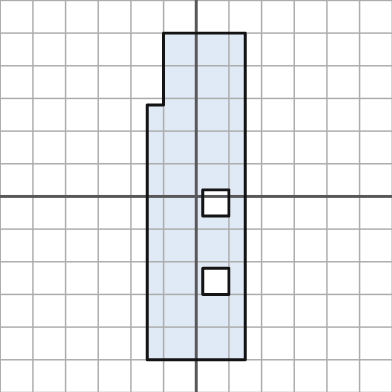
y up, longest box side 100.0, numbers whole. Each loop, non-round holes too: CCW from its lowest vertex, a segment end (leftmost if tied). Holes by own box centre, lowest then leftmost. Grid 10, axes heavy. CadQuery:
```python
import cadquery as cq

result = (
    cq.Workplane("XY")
    .moveTo(-15.0, -50.0)
    .lineTo(15.0, -50.0)
    .lineTo(15.0, 50.0)
    .lineTo(-10.0, 50.0)
    .lineTo(-10.0, 28.0)
    .lineTo(-15.0, 28.0)
    .close()
    .moveTo(2.0, -30.0)
    .lineTo(10.0, -30.0)
    .lineTo(10.0, -22.0)
    .lineTo(2.0, -22.0)
    .close()
    .moveTo(2.0, -6.0)
    .lineTo(10.0, -6.0)
    .lineTo(10.0, 2.0)
    .lineTo(2.0, 2.0)
    .close()
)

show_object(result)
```